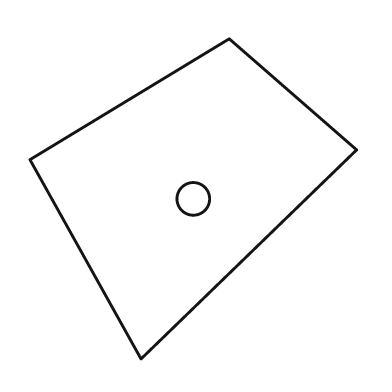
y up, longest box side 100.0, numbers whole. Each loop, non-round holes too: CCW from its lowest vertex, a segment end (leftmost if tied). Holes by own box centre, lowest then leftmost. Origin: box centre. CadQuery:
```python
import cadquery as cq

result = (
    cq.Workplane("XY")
    .moveTo(-16.0, -49.0)
    .lineTo(50.0, 15.0)
    .lineTo(11.0, 49.0)
    .lineTo(-50.0, 12.0)
    .close()
    .moveTo(0.0, 0.0)
    .circle(5.0)
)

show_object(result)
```